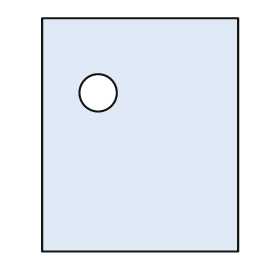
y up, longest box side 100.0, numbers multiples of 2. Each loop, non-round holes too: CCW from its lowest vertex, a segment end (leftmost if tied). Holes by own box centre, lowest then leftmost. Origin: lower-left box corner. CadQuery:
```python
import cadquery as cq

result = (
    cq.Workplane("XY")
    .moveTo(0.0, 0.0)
    .lineTo(84.0, 0.0)
    .lineTo(84.0, 100.0)
    .lineTo(0.0, 100.0)
    .close()
    .moveTo(24.0, 68.0)
    .circle(8.0)
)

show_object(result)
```